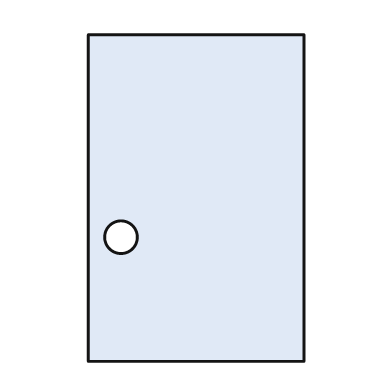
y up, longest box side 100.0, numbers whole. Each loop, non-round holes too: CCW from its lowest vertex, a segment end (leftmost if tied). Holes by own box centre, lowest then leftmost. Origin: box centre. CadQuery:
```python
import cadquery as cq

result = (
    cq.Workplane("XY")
    .moveTo(-33.0, -50.0)
    .lineTo(33.0, -50.0)
    .lineTo(33.0, 50.0)
    .lineTo(-33.0, 50.0)
    .close()
    .moveTo(-23.0, -12.0)
    .circle(5.0)
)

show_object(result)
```